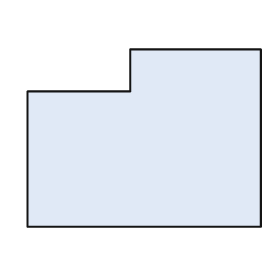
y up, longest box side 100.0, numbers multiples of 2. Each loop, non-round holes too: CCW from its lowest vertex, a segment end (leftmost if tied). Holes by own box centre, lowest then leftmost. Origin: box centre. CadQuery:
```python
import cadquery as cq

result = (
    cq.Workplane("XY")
    .moveTo(-50.0, -38.0)
    .lineTo(50.0, -38.0)
    .lineTo(50.0, 38.0)
    .lineTo(-6.0, 38.0)
    .lineTo(-6.0, 20.0)
    .lineTo(-50.0, 20.0)
    .close()
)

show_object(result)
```